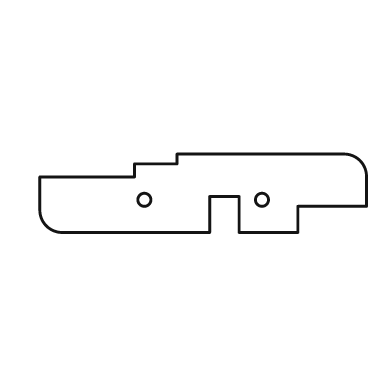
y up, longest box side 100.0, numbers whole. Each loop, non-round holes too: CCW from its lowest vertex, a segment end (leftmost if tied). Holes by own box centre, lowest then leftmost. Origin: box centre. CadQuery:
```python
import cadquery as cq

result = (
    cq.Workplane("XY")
    .moveTo(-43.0, -12.0)
    .lineTo(2.0, -12.0)
    .lineTo(2.0, -1.0)
    .lineTo(11.0, -1.0)
    .lineTo(11.0, -12.0)
    .lineTo(29.0, -12.0)
    .lineTo(29.0, -4.0)
    .lineTo(50.0, -4.0)
    .lineTo(50.0, 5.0)
    .threePointArc((48.0, 10.0), (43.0, 12.0))
    .lineTo(-8.0, 12.0)
    .lineTo(-8.0, 9.0)
    .lineTo(-21.0, 9.0)
    .lineTo(-21.0, 5.0)
    .lineTo(-50.0, 5.0)
    .lineTo(-50.0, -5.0)
    .threePointArc((-48.0, -10.0), (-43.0, -12.0))
    .close()
    .moveTo(-18.0, -2.0)
    .circle(2.0)
    .moveTo(18.0, -2.0)
    .circle(2.0)
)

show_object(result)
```